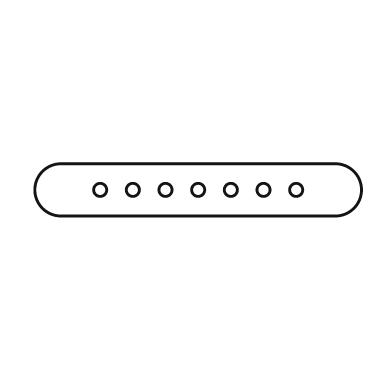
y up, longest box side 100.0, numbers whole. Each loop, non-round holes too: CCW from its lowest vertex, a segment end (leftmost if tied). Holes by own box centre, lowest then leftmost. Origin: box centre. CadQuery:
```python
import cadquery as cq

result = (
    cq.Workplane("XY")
    .moveTo(-42.0, -8.0)
    .lineTo(42.0, -8.0)
    .threePointArc((50.0, 0.0), (42.0, 8.0))
    .lineTo(-42.0, 8.0)
    .threePointArc((-50.0, 0.0), (-42.0, -8.0))
    .close()
    .moveTo(-30.0, 0.0)
    .circle(2.0)
    .moveTo(-20.0, 0.0)
    .circle(2.0)
    .moveTo(-10.0, 0.0)
    .circle(2.0)
    .moveTo(0.0, 0.0)
    .circle(2.0)
    .moveTo(10.0, 0.0)
    .circle(2.0)
    .moveTo(20.0, 0.0)
    .circle(2.0)
    .moveTo(30.0, 0.0)
    .circle(2.0)
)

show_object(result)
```